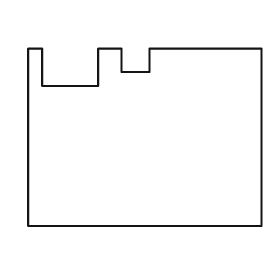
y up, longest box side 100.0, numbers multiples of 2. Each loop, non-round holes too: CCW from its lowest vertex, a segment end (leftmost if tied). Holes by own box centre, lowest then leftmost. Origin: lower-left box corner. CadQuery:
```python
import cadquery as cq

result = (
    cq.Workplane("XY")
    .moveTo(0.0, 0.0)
    .lineTo(100.0, 0.0)
    .lineTo(100.0, 76.0)
    .lineTo(52.0, 76.0)
    .lineTo(52.0, 66.0)
    .lineTo(40.0, 66.0)
    .lineTo(40.0, 76.0)
    .lineTo(30.0, 76.0)
    .lineTo(30.0, 60.0)
    .lineTo(6.0, 60.0)
    .lineTo(6.0, 76.0)
    .lineTo(0.0, 76.0)
    .close()
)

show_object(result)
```